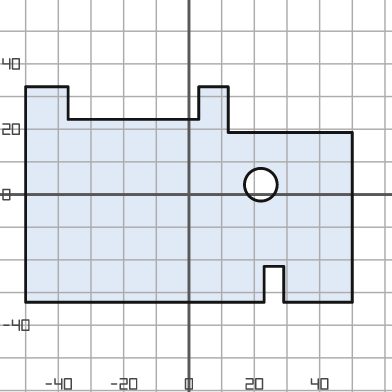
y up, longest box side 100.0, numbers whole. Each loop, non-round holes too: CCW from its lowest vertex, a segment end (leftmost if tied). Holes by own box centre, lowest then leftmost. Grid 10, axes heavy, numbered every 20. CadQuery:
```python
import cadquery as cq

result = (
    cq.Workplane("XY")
    .moveTo(-50.0, -33.0)
    .lineTo(23.0, -33.0)
    .lineTo(23.0, -22.0)
    .lineTo(29.0, -22.0)
    .lineTo(29.0, -33.0)
    .lineTo(50.0, -33.0)
    .lineTo(50.0, 19.0)
    .lineTo(12.0, 19.0)
    .lineTo(12.0, 33.0)
    .lineTo(3.0, 33.0)
    .lineTo(3.0, 23.0)
    .lineTo(-37.0, 23.0)
    .lineTo(-37.0, 33.0)
    .lineTo(-50.0, 33.0)
    .close()
    .moveTo(22.0, 3.0)
    .circle(5.0)
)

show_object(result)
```